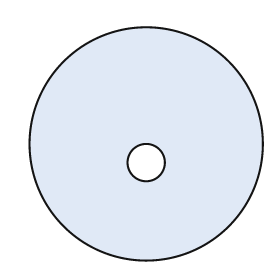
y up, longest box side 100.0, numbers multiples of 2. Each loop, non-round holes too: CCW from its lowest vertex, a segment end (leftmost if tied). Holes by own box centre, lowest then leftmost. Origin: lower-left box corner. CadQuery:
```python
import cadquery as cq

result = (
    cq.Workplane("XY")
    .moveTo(50.0, 50.0)
    .circle(50.0)
    .moveTo(50.0, 42.0)
    .circle(8.0)
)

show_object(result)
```